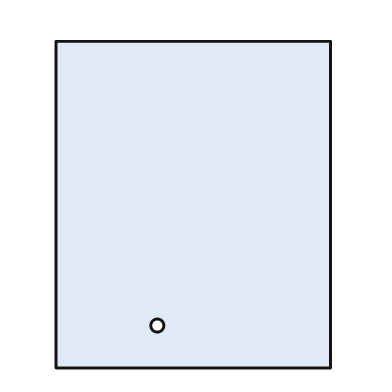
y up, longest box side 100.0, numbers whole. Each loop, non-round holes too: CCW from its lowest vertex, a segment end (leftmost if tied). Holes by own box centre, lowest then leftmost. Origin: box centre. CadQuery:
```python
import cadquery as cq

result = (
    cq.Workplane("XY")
    .moveTo(-42.0, -50.0)
    .lineTo(42.0, -50.0)
    .lineTo(42.0, 50.0)
    .lineTo(-42.0, 50.0)
    .close()
    .moveTo(-11.0, -37.0)
    .circle(2.0)
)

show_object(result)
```